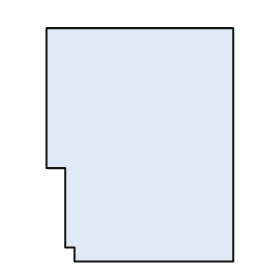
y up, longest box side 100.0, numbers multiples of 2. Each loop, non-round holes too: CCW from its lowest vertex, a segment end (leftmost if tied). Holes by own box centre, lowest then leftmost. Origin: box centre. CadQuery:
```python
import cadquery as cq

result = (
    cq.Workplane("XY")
    .moveTo(-28.0, -50.0)
    .lineTo(40.0, -50.0)
    .lineTo(40.0, 50.0)
    .lineTo(-40.0, 50.0)
    .lineTo(-40.0, -10.0)
    .lineTo(-32.0, -10.0)
    .lineTo(-32.0, -44.0)
    .lineTo(-28.0, -44.0)
    .close()
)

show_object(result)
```